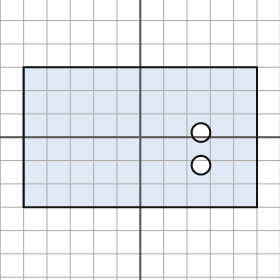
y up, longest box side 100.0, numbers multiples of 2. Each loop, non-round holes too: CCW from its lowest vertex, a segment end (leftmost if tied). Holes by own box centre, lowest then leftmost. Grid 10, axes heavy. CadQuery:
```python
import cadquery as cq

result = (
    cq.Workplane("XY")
    .moveTo(-50.0, -30.0)
    .lineTo(50.0, -30.0)
    .lineTo(50.0, 30.0)
    .lineTo(-50.0, 30.0)
    .close()
    .moveTo(26.0, -12.0)
    .circle(4.0)
    .moveTo(26.0, 2.0)
    .circle(4.0)
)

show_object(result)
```